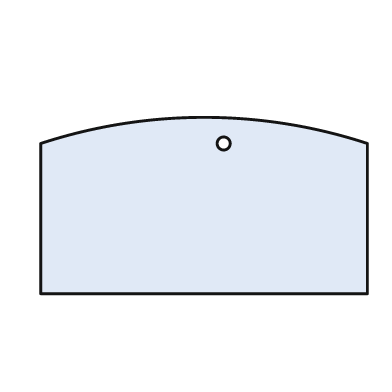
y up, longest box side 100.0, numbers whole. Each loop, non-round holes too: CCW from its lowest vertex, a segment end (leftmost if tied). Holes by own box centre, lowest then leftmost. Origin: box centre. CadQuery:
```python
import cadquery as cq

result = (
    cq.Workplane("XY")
    .moveTo(-50.0, -27.0)
    .lineTo(50.0, -27.0)
    .lineTo(50.0, 19.0)
    .threePointArc((0.0, 27.0), (-50.0, 19.0))
    .close()
    .moveTo(6.0, 19.0)
    .circle(2.0)
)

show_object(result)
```